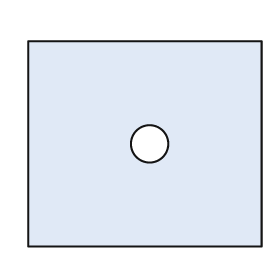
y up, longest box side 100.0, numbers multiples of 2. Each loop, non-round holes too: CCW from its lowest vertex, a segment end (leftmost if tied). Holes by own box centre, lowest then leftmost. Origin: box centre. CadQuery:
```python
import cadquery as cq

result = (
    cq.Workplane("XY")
    .moveTo(-50.0, -44.0)
    .lineTo(50.0, -44.0)
    .lineTo(50.0, 44.0)
    .lineTo(-50.0, 44.0)
    .close()
    .moveTo(2.0, 0.0)
    .circle(8.0)
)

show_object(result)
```